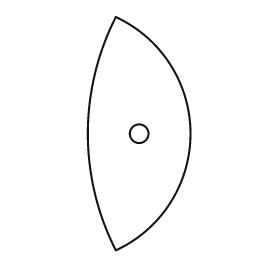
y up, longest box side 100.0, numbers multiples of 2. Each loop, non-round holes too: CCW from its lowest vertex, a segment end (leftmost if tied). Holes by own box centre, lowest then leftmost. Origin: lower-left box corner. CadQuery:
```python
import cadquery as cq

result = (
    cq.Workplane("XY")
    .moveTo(12.0, 0.0)
    .threePointArc((44.0, 50.0), (12.0, 100.0))
    .threePointArc((0.0, 50.0), (12.0, 0.0))
    .close()
    .moveTo(22.0, 50.0)
    .circle(4.0)
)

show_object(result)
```